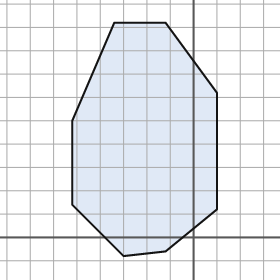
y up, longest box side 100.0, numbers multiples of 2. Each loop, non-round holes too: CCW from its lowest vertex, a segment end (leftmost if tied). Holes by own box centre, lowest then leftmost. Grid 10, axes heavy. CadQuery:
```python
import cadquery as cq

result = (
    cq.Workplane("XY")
    .moveTo(-30.0, -8.0)
    .lineTo(-12.0, -6.0)
    .lineTo(10.0, 12.0)
    .lineTo(10.0, 62.0)
    .lineTo(-12.0, 92.0)
    .lineTo(-34.0, 92.0)
    .lineTo(-52.0, 50.0)
    .lineTo(-52.0, 14.0)
    .close()
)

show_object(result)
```